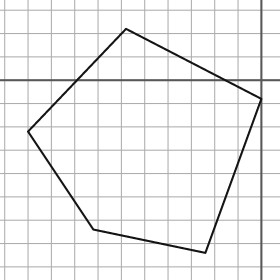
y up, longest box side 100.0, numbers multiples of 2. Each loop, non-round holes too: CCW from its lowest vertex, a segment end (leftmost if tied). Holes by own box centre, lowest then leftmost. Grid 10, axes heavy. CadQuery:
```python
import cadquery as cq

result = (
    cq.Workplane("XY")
    .moveTo(-24.0, -74.0)
    .lineTo(0.0, -8.0)
    .lineTo(-58.0, 22.0)
    .lineTo(-100.0, -22.0)
    .lineTo(-72.0, -64.0)
    .close()
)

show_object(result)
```